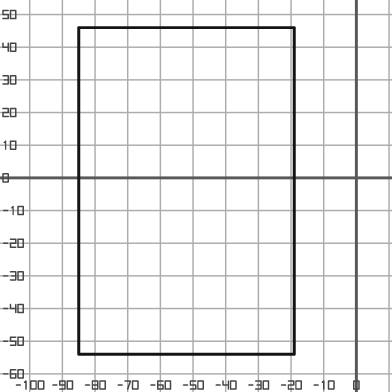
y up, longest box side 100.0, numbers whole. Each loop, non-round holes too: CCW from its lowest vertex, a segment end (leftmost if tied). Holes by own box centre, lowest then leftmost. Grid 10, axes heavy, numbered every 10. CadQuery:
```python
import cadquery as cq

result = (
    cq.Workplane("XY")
    .moveTo(-85.0, -54.0)
    .lineTo(-19.0, -54.0)
    .lineTo(-19.0, 46.0)
    .lineTo(-85.0, 46.0)
    .close()
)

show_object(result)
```